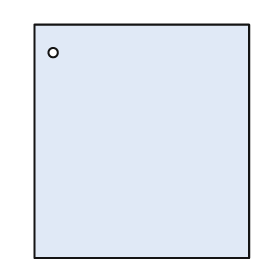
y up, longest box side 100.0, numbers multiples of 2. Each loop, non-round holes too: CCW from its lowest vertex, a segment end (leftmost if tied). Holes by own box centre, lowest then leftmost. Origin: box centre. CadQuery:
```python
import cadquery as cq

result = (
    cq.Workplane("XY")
    .moveTo(-46.0, -50.0)
    .lineTo(46.0, -50.0)
    .lineTo(46.0, 50.0)
    .lineTo(-46.0, 50.0)
    .close()
    .moveTo(-38.0, 38.0)
    .circle(2.0)
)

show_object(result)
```